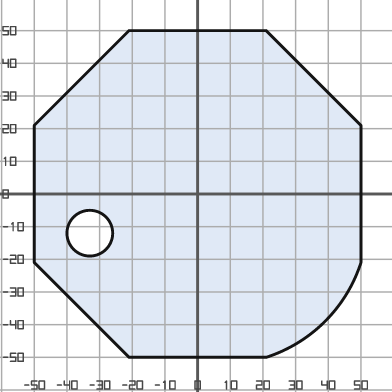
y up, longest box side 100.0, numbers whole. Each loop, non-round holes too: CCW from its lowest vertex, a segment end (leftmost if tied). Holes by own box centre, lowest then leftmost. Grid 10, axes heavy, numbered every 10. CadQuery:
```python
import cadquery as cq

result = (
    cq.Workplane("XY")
    .moveTo(-21.0, -50.0)
    .lineTo(21.0, -50.0)
    .threePointArc((39.0, -39.0), (50.0, -21.0))
    .lineTo(50.0, 21.0)
    .lineTo(21.0, 50.0)
    .lineTo(-21.0, 50.0)
    .lineTo(-50.0, 21.0)
    .lineTo(-50.0, -21.0)
    .close()
    .moveTo(-33.0, -12.0)
    .circle(7.0)
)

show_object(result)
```